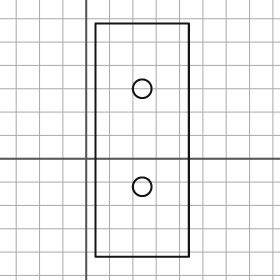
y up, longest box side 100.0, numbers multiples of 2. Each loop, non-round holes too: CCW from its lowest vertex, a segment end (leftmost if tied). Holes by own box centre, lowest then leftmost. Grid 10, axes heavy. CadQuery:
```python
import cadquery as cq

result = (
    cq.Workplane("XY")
    .moveTo(4.0, -42.0)
    .lineTo(44.0, -42.0)
    .lineTo(44.0, 58.0)
    .lineTo(4.0, 58.0)
    .close()
    .moveTo(24.0, -12.0)
    .circle(4.0)
    .moveTo(24.0, 30.0)
    .circle(4.0)
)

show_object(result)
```